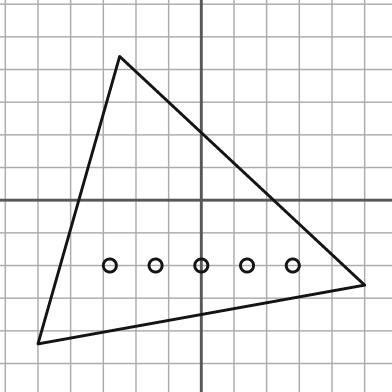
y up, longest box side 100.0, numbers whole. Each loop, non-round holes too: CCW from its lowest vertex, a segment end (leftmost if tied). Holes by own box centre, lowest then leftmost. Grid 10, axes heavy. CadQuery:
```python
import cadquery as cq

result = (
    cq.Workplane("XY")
    .moveTo(-50.0, -44.0)
    .lineTo(50.0, -26.0)
    .lineTo(-25.0, 44.0)
    .close()
    .moveTo(-28.0, -20.0)
    .circle(2.0)
    .moveTo(-14.0, -20.0)
    .circle(2.0)
    .moveTo(0.0, -20.0)
    .circle(2.0)
    .moveTo(14.0, -20.0)
    .circle(2.0)
    .moveTo(28.0, -20.0)
    .circle(2.0)
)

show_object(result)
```